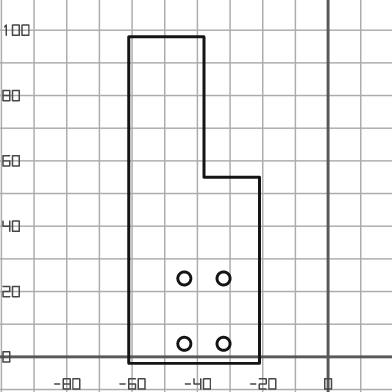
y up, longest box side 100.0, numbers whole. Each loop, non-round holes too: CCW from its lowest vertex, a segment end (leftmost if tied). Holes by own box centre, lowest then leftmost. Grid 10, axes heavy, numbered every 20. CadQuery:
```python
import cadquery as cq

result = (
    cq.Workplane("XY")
    .moveTo(-61.0, -2.0)
    .lineTo(-21.0, -2.0)
    .lineTo(-21.0, 55.0)
    .lineTo(-38.0, 55.0)
    .lineTo(-38.0, 98.0)
    .lineTo(-61.0, 98.0)
    .close()
    .moveTo(-44.0, 4.0)
    .circle(2.0)
    .moveTo(-32.0, 4.0)
    .circle(2.0)
    .moveTo(-44.0, 24.0)
    .circle(2.0)
    .moveTo(-32.0, 24.0)
    .circle(2.0)
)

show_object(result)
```